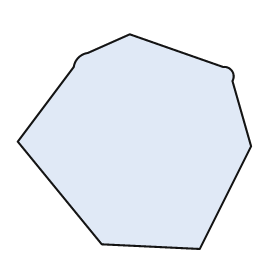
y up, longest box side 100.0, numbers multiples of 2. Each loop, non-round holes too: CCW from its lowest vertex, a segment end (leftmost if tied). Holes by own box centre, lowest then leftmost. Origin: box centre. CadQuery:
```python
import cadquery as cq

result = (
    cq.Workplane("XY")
    .moveTo(28.0, -46.0)
    .lineTo(50.0, -2.0)
    .lineTo(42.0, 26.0)
    .threePointArc((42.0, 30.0), (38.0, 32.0))
    .lineTo(-2.0, 46.0)
    .lineTo(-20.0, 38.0)
    .threePointArc((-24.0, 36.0), (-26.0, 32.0))
    .lineTo(-50.0, 0.0)
    .lineTo(-14.0, -44.0)
    .close()
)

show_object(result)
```